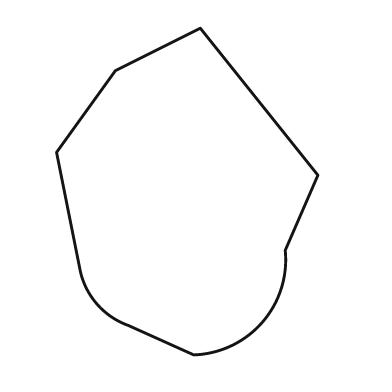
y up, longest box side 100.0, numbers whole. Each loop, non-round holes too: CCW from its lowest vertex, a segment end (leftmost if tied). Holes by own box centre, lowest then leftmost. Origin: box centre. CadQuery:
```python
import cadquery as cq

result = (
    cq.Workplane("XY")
    .moveTo(2.0, -50.0)
    .threePointArc((23.0, -40.0), (30.0, -18.0))
    .lineTo(40.0, 5.0)
    .lineTo(4.0, 50.0)
    .lineTo(-22.0, 37.0)
    .lineTo(-40.0, 12.0)
    .lineTo(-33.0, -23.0)
    .threePointArc((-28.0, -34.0), (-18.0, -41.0))
    .close()
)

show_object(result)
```